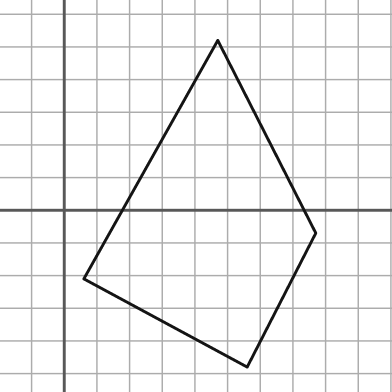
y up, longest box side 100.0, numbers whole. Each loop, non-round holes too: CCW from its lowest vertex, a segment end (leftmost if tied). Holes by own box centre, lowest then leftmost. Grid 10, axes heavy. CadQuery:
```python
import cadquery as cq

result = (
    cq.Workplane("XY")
    .moveTo(56.0, -48.0)
    .lineTo(77.0, -7.0)
    .lineTo(47.0, 52.0)
    .lineTo(6.0, -21.0)
    .close()
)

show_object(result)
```